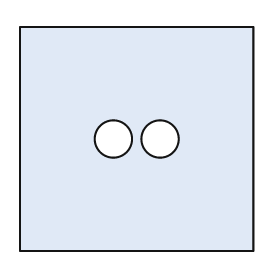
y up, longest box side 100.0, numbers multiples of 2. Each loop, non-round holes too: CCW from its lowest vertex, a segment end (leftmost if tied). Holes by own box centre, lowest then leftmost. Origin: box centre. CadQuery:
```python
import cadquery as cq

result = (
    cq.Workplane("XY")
    .moveTo(-50.0, -48.0)
    .lineTo(50.0, -48.0)
    .lineTo(50.0, 48.0)
    .lineTo(-50.0, 48.0)
    .close()
    .moveTo(-10.0, 0.0)
    .circle(8.0)
    .moveTo(10.0, 0.0)
    .circle(8.0)
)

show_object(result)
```